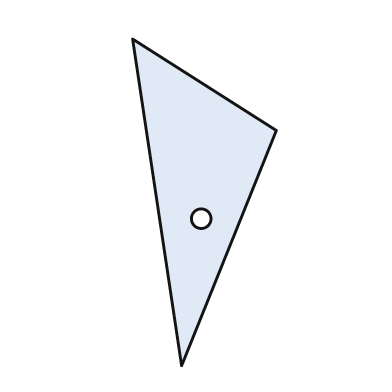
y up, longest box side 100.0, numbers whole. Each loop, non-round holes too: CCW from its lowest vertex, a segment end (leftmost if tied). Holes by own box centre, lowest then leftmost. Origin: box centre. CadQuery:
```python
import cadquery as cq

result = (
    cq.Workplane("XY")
    .moveTo(-7.0, -50.0)
    .lineTo(22.0, 22.0)
    .lineTo(-22.0, 50.0)
    .close()
    .moveTo(-1.0, -5.0)
    .circle(3.0)
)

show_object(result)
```